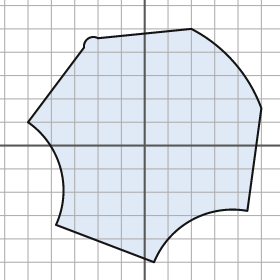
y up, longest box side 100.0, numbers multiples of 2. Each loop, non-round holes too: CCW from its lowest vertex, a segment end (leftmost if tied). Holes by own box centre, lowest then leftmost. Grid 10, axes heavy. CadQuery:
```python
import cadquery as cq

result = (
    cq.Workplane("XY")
    .moveTo(4.0, -50.0)
    .threePointArc((20.0, -32.0), (44.0, -28.0))
    .lineTo(50.0, 16.0)
    .threePointArc((38.0, 36.0), (20.0, 50.0))
    .lineTo(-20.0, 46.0)
    .threePointArc((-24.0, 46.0), (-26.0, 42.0))
    .lineTo(-50.0, 10.0)
    .threePointArc((-36.0, -10.0), (-38.0, -34.0))
    .close()
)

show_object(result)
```